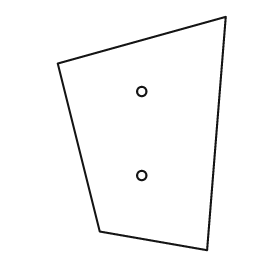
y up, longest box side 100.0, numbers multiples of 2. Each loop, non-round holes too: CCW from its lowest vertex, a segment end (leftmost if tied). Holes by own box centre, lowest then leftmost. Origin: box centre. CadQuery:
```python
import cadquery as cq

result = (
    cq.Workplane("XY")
    .moveTo(28.0, -50.0)
    .lineTo(36.0, 50.0)
    .lineTo(-36.0, 30.0)
    .lineTo(-18.0, -42.0)
    .close()
    .moveTo(0.0, -18.0)
    .circle(2.0)
    .moveTo(0.0, 18.0)
    .circle(2.0)
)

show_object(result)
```